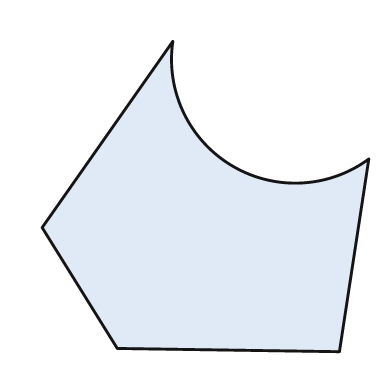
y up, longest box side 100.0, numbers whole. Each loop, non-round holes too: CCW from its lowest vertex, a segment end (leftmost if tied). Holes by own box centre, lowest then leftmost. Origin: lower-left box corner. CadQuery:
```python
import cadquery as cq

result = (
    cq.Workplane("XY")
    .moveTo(91.0, 0.0)
    .lineTo(100.0, 59.0)
    .threePointArc((58.0, 57.0), (40.0, 95.0))
    .lineTo(0.0, 38.0)
    .lineTo(23.0, 1.0)
    .close()
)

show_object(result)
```